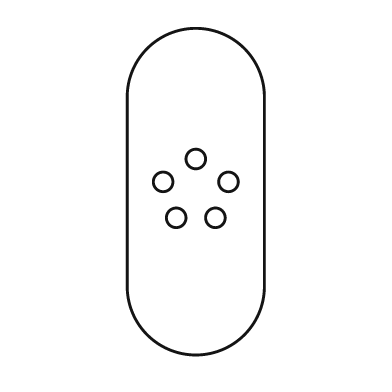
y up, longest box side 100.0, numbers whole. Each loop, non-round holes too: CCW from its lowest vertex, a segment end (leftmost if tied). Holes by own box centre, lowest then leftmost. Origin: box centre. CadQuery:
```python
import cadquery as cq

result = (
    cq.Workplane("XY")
    .moveTo(-21.0, -29.0)
    .threePointArc((0.0, -50.0), (21.0, -29.0))
    .lineTo(21.0, 29.0)
    .threePointArc((0.0, 50.0), (-21.0, 29.0))
    .close()
    .moveTo(-6.0, -8.0)
    .circle(3.0)
    .moveTo(6.0, -8.0)
    .circle(3.0)
    .moveTo(-10.0, 3.0)
    .circle(3.0)
    .moveTo(10.0, 3.0)
    .circle(3.0)
    .moveTo(0.0, 10.0)
    .circle(3.0)
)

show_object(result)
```